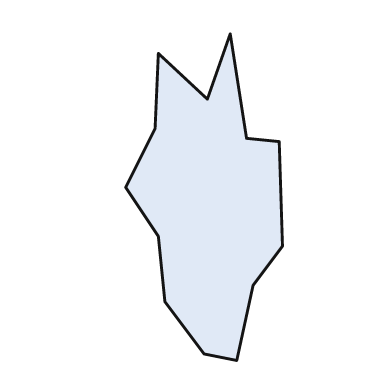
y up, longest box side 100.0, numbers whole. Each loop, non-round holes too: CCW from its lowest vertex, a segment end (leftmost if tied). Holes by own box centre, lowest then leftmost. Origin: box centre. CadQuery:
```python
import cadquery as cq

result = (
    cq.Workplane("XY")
    .moveTo(10.0, -50.0)
    .lineTo(15.0, -27.0)
    .lineTo(24.0, -15.0)
    .lineTo(23.0, 17.0)
    .lineTo(13.0, 18.0)
    .lineTo(8.0, 50.0)
    .lineTo(1.0, 30.0)
    .lineTo(-14.0, 44.0)
    .lineTo(-15.0, 21.0)
    .lineTo(-24.0, 3.0)
    .lineTo(-14.0, -12.0)
    .lineTo(-12.0, -32.0)
    .lineTo(0.0, -48.0)
    .close()
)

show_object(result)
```